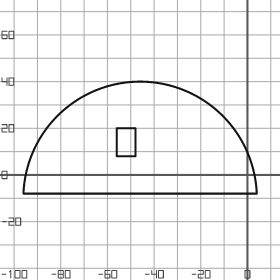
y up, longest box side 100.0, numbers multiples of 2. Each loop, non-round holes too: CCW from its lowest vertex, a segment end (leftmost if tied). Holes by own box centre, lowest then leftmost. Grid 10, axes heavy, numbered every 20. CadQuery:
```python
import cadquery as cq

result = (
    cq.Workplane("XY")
    .moveTo(-96.0, -8.0)
    .lineTo(4.0, -8.0)
    .threePointArc((-46.0, 40.0), (-96.0, -8.0))
    .close()
    .moveTo(-56.0, 8.0)
    .lineTo(-48.0, 8.0)
    .lineTo(-48.0, 20.0)
    .lineTo(-56.0, 20.0)
    .close()
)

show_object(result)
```